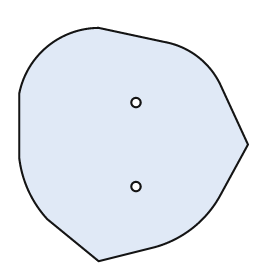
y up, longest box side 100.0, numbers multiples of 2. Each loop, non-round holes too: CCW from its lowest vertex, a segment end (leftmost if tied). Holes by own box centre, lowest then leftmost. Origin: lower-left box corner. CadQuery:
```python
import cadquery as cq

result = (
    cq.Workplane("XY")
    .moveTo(34.0, 0.0)
    .lineTo(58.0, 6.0)
    .threePointArc((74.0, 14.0), (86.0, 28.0))
    .lineTo(98.0, 50.0)
    .lineTo(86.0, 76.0)
    .threePointArc((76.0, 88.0), (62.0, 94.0))
    .lineTo(34.0, 100.0)
    .threePointArc((12.0, 92.0), (0.0, 72.0))
    .lineTo(0.0, 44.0)
    .threePointArc((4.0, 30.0), (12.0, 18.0))
    .close()
    .moveTo(50.0, 32.0)
    .circle(2.0)
    .moveTo(50.0, 68.0)
    .circle(2.0)
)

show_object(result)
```